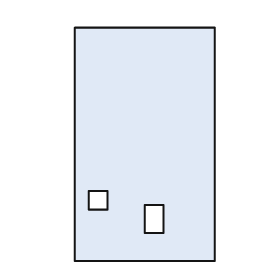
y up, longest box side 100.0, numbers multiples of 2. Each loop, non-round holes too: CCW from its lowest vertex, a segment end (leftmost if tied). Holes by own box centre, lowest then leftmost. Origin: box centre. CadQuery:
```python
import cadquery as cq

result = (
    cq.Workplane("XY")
    .moveTo(-30.0, -50.0)
    .lineTo(30.0, -50.0)
    .lineTo(30.0, 50.0)
    .lineTo(-30.0, 50.0)
    .close()
    .moveTo(0.0, -38.0)
    .lineTo(8.0, -38.0)
    .lineTo(8.0, -26.0)
    .lineTo(0.0, -26.0)
    .close()
    .moveTo(-24.0, -28.0)
    .lineTo(-16.0, -28.0)
    .lineTo(-16.0, -20.0)
    .lineTo(-24.0, -20.0)
    .close()
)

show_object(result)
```